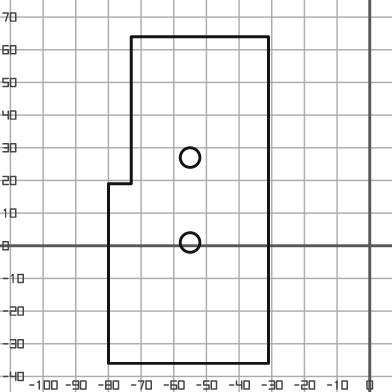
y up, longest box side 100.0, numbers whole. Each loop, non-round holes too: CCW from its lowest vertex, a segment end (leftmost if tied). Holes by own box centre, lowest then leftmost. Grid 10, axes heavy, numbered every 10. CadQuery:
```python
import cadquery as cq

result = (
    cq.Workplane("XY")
    .moveTo(-80.0, -36.0)
    .lineTo(-31.0, -36.0)
    .lineTo(-31.0, 64.0)
    .lineTo(-73.0, 64.0)
    .lineTo(-73.0, 19.0)
    .lineTo(-80.0, 19.0)
    .close()
    .moveTo(-55.0, 1.0)
    .circle(3.0)
    .moveTo(-55.0, 27.0)
    .circle(3.0)
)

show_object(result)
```